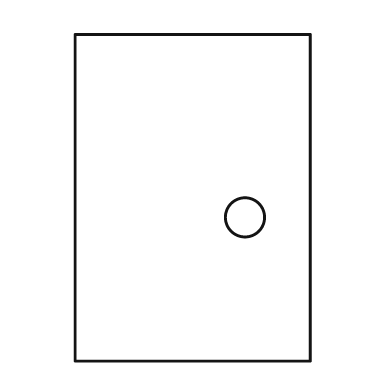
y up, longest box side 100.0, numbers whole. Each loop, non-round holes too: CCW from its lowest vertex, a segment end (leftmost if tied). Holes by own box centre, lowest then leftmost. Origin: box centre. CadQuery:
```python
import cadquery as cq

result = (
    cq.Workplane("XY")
    .moveTo(-36.0, -50.0)
    .lineTo(36.0, -50.0)
    .lineTo(36.0, 50.0)
    .lineTo(-36.0, 50.0)
    .close()
    .moveTo(16.0, -6.0)
    .circle(6.0)
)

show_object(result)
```